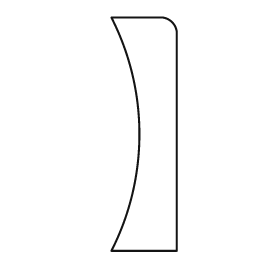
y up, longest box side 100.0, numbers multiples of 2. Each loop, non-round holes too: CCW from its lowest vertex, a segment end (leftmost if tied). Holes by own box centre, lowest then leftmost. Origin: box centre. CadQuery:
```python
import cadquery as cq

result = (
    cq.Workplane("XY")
    .moveTo(-14.0, -50.0)
    .lineTo(14.0, -50.0)
    .lineTo(14.0, 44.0)
    .threePointArc((12.0, 48.0), (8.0, 50.0))
    .lineTo(-14.0, 50.0)
    .threePointArc((-2.0, 0.0), (-14.0, -50.0))
    .close()
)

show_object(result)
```